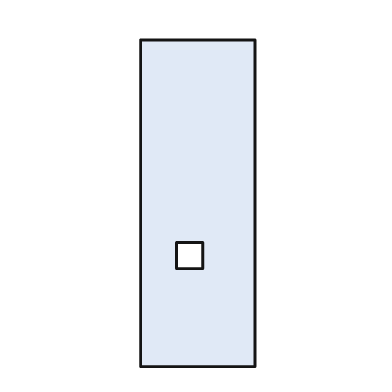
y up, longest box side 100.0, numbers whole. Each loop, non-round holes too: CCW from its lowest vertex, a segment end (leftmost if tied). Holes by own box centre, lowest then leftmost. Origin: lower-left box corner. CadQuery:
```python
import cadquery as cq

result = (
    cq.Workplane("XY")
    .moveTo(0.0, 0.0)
    .lineTo(35.0, 0.0)
    .lineTo(35.0, 100.0)
    .lineTo(0.0, 100.0)
    .close()
    .moveTo(11.0, 30.0)
    .lineTo(19.0, 30.0)
    .lineTo(19.0, 38.0)
    .lineTo(11.0, 38.0)
    .close()
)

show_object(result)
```